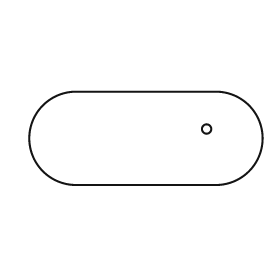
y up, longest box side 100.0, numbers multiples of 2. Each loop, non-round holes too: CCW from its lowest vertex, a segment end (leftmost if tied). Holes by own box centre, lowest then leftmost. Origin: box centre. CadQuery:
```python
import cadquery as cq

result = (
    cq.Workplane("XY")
    .moveTo(-30.0, -20.0)
    .lineTo(30.0, -20.0)
    .threePointArc((50.0, 0.0), (30.0, 20.0))
    .lineTo(-30.0, 20.0)
    .threePointArc((-50.0, 0.0), (-30.0, -20.0))
    .close()
    .moveTo(26.0, 4.0)
    .circle(2.0)
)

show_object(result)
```